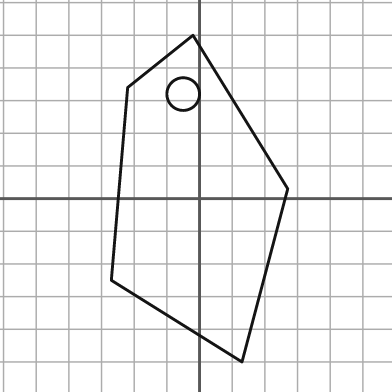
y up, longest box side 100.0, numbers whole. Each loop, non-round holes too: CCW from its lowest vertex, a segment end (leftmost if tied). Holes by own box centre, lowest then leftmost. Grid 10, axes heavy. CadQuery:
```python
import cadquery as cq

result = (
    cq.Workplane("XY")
    .moveTo(13.0, -50.0)
    .lineTo(27.0, 3.0)
    .lineTo(-2.0, 50.0)
    .lineTo(-22.0, 34.0)
    .lineTo(-27.0, -25.0)
    .close()
    .moveTo(-5.0, 32.0)
    .circle(5.0)
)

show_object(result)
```